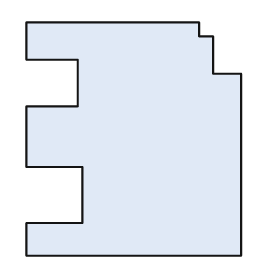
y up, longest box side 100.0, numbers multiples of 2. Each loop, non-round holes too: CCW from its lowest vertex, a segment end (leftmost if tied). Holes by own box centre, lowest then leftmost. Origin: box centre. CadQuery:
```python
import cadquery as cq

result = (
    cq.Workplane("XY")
    .moveTo(-46.0, -50.0)
    .lineTo(46.0, -50.0)
    .lineTo(46.0, 28.0)
    .lineTo(34.0, 28.0)
    .lineTo(34.0, 44.0)
    .lineTo(28.0, 44.0)
    .lineTo(28.0, 50.0)
    .lineTo(-46.0, 50.0)
    .lineTo(-46.0, 34.0)
    .lineTo(-24.0, 34.0)
    .lineTo(-24.0, 14.0)
    .lineTo(-46.0, 14.0)
    .lineTo(-46.0, -12.0)
    .lineTo(-22.0, -12.0)
    .lineTo(-22.0, -36.0)
    .lineTo(-46.0, -36.0)
    .close()
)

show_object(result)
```